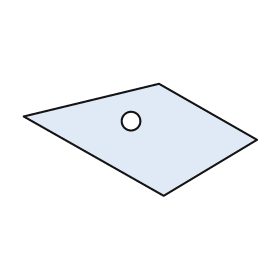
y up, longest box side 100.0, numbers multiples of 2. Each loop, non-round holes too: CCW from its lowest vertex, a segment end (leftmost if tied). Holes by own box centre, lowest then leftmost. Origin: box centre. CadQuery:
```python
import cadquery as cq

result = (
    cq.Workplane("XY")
    .moveTo(10.0, -24.0)
    .lineTo(50.0, 0.0)
    .lineTo(8.0, 24.0)
    .lineTo(-50.0, 10.0)
    .close()
    .moveTo(-4.0, 8.0)
    .circle(4.0)
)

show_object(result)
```